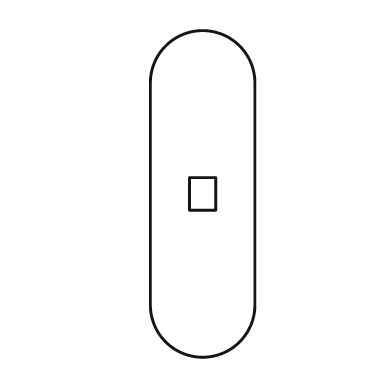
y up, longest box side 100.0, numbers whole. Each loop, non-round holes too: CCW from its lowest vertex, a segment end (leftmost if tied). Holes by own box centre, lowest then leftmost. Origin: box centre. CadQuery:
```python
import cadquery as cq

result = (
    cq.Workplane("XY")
    .moveTo(-16.0, -34.0)
    .threePointArc((0.0, -50.0), (16.0, -34.0))
    .lineTo(16.0, 34.0)
    .threePointArc((0.0, 50.0), (-16.0, 34.0))
    .close()
    .moveTo(-4.0, -5.0)
    .lineTo(4.0, -5.0)
    .lineTo(4.0, 5.0)
    .lineTo(-4.0, 5.0)
    .close()
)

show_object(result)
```